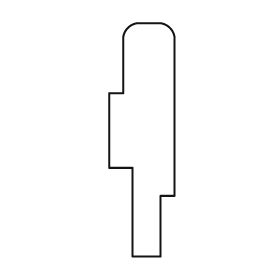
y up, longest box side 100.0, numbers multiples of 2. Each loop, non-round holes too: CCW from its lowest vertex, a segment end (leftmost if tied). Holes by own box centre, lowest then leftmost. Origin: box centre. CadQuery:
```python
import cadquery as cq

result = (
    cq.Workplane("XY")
    .moveTo(-4.0, -50.0)
    .lineTo(8.0, -50.0)
    .lineTo(8.0, -24.0)
    .lineTo(14.0, -24.0)
    .lineTo(14.0, 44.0)
    .threePointArc((12.0, 48.0), (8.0, 50.0))
    .lineTo(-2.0, 50.0)
    .threePointArc((-6.0, 48.0), (-8.0, 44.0))
    .lineTo(-8.0, 20.0)
    .lineTo(-14.0, 20.0)
    .lineTo(-14.0, -12.0)
    .lineTo(-4.0, -12.0)
    .close()
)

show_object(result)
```